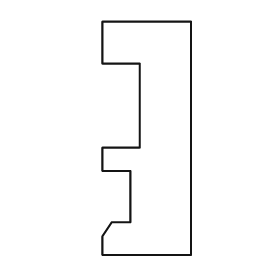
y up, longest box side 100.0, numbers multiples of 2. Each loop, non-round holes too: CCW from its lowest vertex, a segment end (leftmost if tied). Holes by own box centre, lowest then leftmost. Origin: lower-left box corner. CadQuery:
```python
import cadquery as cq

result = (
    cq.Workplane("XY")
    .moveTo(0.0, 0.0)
    .lineTo(38.0, 0.0)
    .lineTo(38.0, 100.0)
    .lineTo(0.0, 100.0)
    .lineTo(0.0, 82.0)
    .lineTo(16.0, 82.0)
    .lineTo(16.0, 46.0)
    .lineTo(0.0, 46.0)
    .lineTo(0.0, 36.0)
    .lineTo(12.0, 36.0)
    .lineTo(12.0, 14.0)
    .lineTo(4.0, 14.0)
    .lineTo(0.0, 8.0)
    .close()
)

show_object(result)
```